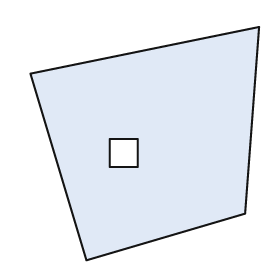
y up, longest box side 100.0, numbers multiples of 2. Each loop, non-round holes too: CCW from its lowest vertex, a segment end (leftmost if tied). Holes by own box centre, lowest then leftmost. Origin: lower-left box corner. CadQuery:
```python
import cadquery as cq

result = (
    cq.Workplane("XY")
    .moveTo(24.0, 0.0)
    .lineTo(92.0, 20.0)
    .lineTo(98.0, 100.0)
    .lineTo(0.0, 80.0)
    .close()
    .moveTo(34.0, 40.0)
    .lineTo(46.0, 40.0)
    .lineTo(46.0, 52.0)
    .lineTo(34.0, 52.0)
    .close()
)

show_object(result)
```